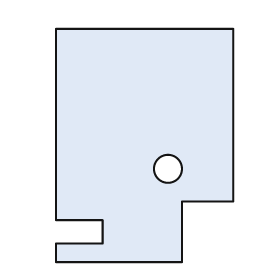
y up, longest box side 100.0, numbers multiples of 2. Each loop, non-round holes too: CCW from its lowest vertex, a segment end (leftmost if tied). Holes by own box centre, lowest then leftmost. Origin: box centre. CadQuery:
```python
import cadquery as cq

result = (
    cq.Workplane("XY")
    .moveTo(-38.0, -50.0)
    .lineTo(16.0, -50.0)
    .lineTo(16.0, -24.0)
    .lineTo(38.0, -24.0)
    .lineTo(38.0, 50.0)
    .lineTo(-38.0, 50.0)
    .lineTo(-38.0, -32.0)
    .lineTo(-18.0, -32.0)
    .lineTo(-18.0, -42.0)
    .lineTo(-38.0, -42.0)
    .close()
    .moveTo(10.0, -10.0)
    .circle(6.0)
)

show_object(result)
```